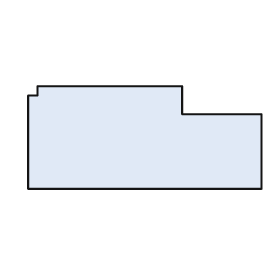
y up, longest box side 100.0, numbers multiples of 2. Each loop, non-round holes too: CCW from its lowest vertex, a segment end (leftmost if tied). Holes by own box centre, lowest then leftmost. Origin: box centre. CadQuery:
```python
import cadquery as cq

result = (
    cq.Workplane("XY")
    .moveTo(-50.0, -22.0)
    .lineTo(50.0, -22.0)
    .lineTo(50.0, 10.0)
    .lineTo(16.0, 10.0)
    .lineTo(16.0, 22.0)
    .lineTo(-46.0, 22.0)
    .lineTo(-46.0, 18.0)
    .lineTo(-50.0, 18.0)
    .close()
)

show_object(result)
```